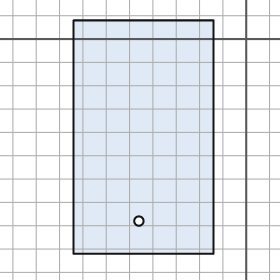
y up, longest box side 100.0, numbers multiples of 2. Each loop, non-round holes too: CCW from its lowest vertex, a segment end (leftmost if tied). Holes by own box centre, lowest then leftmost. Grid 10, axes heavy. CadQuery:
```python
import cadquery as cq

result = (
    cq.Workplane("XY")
    .moveTo(-74.0, -92.0)
    .lineTo(-14.0, -92.0)
    .lineTo(-14.0, 8.0)
    .lineTo(-74.0, 8.0)
    .close()
    .moveTo(-46.0, -78.0)
    .circle(2.0)
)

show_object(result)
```